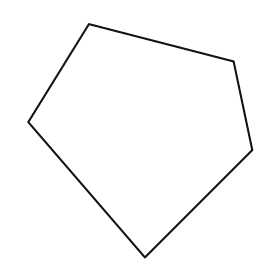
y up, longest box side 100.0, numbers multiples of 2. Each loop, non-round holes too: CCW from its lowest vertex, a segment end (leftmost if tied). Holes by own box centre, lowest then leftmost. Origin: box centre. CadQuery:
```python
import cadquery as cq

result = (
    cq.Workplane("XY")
    .moveTo(2.0, -50.0)
    .lineTo(48.0, -4.0)
    .lineTo(40.0, 34.0)
    .lineTo(-22.0, 50.0)
    .lineTo(-48.0, 8.0)
    .close()
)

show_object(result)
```